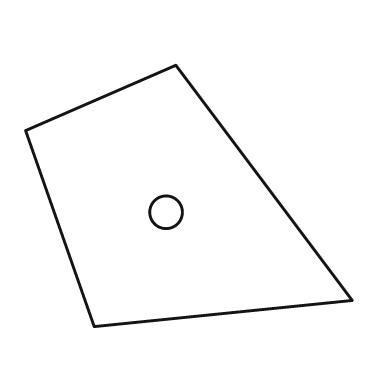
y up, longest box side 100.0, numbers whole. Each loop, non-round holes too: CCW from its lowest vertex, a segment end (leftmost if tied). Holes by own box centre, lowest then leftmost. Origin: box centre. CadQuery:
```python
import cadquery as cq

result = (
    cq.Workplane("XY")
    .moveTo(-29.0, -40.0)
    .lineTo(50.0, -32.0)
    .lineTo(-4.0, 40.0)
    .lineTo(-50.0, 20.0)
    .close()
    .moveTo(-7.0, -5.0)
    .circle(5.0)
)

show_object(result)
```